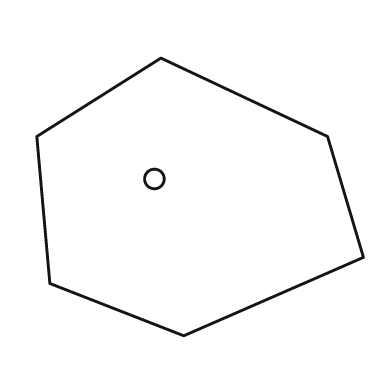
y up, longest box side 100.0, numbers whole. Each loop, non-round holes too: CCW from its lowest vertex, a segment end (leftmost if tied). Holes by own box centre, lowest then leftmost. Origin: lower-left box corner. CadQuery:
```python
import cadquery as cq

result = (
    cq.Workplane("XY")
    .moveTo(45.0, 0.0)
    .lineTo(100.0, 24.0)
    .lineTo(89.0, 61.0)
    .lineTo(38.0, 85.0)
    .lineTo(0.0, 61.0)
    .lineTo(4.0, 16.0)
    .close()
    .moveTo(36.0, 48.0)
    .circle(3.0)
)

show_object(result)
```